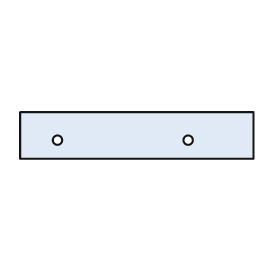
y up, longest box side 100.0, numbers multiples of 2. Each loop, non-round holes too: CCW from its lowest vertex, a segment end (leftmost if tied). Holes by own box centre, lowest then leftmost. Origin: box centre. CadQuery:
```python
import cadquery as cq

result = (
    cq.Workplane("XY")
    .moveTo(-50.0, -10.0)
    .lineTo(50.0, -10.0)
    .lineTo(50.0, 10.0)
    .lineTo(-50.0, 10.0)
    .close()
    .moveTo(-34.0, -2.0)
    .circle(2.0)
    .moveTo(22.0, -2.0)
    .circle(2.0)
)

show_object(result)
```